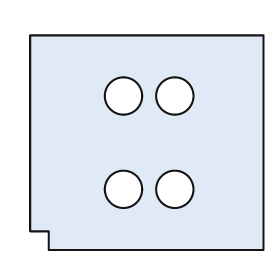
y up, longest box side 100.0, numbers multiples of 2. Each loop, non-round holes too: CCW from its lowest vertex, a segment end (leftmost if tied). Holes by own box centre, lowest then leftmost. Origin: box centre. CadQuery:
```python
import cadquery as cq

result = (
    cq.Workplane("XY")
    .moveTo(-42.0, -46.0)
    .lineTo(50.0, -46.0)
    .lineTo(50.0, 46.0)
    .lineTo(-50.0, 46.0)
    .lineTo(-50.0, -38.0)
    .lineTo(-42.0, -38.0)
    .close()
    .moveTo(-10.0, -20.0)
    .circle(8.0)
    .moveTo(12.0, -20.0)
    .circle(8.0)
    .moveTo(-10.0, 20.0)
    .circle(8.0)
    .moveTo(12.0, 20.0)
    .circle(8.0)
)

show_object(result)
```